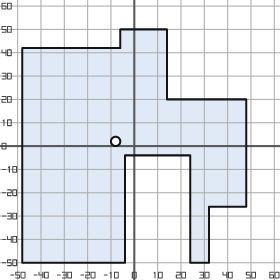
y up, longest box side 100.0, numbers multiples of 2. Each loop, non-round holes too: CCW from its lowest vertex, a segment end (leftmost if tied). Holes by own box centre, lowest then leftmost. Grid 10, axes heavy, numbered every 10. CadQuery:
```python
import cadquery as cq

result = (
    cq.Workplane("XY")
    .moveTo(-48.0, -50.0)
    .lineTo(-4.0, -50.0)
    .lineTo(-4.0, -4.0)
    .lineTo(24.0, -4.0)
    .lineTo(24.0, -50.0)
    .lineTo(32.0, -50.0)
    .lineTo(32.0, -26.0)
    .lineTo(48.0, -26.0)
    .lineTo(48.0, 20.0)
    .lineTo(14.0, 20.0)
    .lineTo(14.0, 50.0)
    .lineTo(-6.0, 50.0)
    .lineTo(-6.0, 42.0)
    .lineTo(-48.0, 42.0)
    .close()
    .moveTo(-8.0, 2.0)
    .circle(2.0)
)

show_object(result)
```